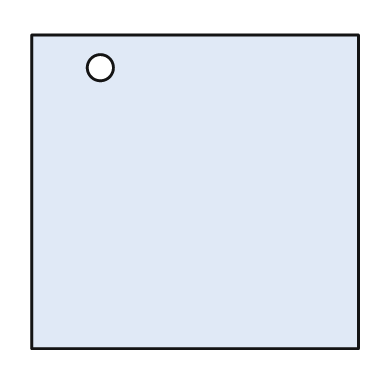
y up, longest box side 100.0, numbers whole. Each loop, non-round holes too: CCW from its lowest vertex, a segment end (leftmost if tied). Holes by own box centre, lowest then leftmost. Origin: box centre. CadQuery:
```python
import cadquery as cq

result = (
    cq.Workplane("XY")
    .moveTo(-50.0, -48.0)
    .lineTo(50.0, -48.0)
    .lineTo(50.0, 48.0)
    .lineTo(-50.0, 48.0)
    .close()
    .moveTo(-29.0, 38.0)
    .circle(4.0)
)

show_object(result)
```